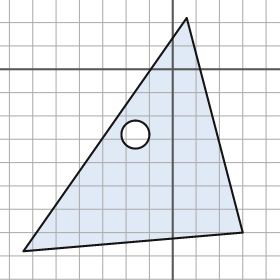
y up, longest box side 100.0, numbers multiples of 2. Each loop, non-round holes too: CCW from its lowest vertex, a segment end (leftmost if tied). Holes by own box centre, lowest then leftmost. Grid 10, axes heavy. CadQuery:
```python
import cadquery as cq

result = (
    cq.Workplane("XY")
    .moveTo(-64.0, -78.0)
    .lineTo(30.0, -70.0)
    .lineTo(6.0, 22.0)
    .close()
    .moveTo(-16.0, -28.0)
    .circle(6.0)
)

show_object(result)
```